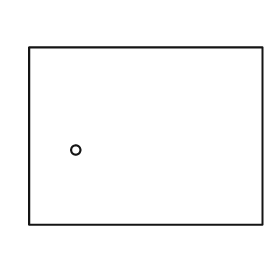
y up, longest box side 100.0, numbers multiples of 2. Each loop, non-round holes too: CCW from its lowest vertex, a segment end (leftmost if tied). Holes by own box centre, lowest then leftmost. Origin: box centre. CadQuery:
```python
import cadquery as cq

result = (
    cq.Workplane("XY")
    .moveTo(-50.0, -38.0)
    .lineTo(50.0, -38.0)
    .lineTo(50.0, 38.0)
    .lineTo(-50.0, 38.0)
    .close()
    .moveTo(-30.0, -6.0)
    .circle(2.0)
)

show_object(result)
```